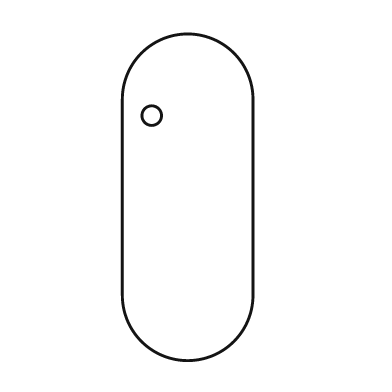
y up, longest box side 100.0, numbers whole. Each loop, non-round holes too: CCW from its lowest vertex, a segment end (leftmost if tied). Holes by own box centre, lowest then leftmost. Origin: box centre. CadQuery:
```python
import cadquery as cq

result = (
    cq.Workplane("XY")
    .moveTo(-20.0, -30.0)
    .threePointArc((0.0, -50.0), (20.0, -30.0))
    .lineTo(20.0, 30.0)
    .threePointArc((0.0, 50.0), (-20.0, 30.0))
    .close()
    .moveTo(-11.0, 25.0)
    .circle(3.0)
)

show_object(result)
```